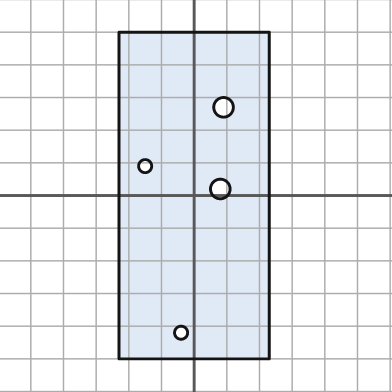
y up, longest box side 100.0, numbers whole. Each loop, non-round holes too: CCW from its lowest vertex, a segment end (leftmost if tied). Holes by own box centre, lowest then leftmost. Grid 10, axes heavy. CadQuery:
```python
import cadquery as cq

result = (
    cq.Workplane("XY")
    .moveTo(-23.0, -50.0)
    .lineTo(23.0, -50.0)
    .lineTo(23.0, 50.0)
    .lineTo(-23.0, 50.0)
    .close()
    .moveTo(-4.0, -42.0)
    .circle(2.0)
    .moveTo(8.0, 2.0)
    .circle(3.0)
    .moveTo(-15.0, 9.0)
    .circle(2.0)
    .moveTo(9.0, 27.0)
    .circle(3.0)
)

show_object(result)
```